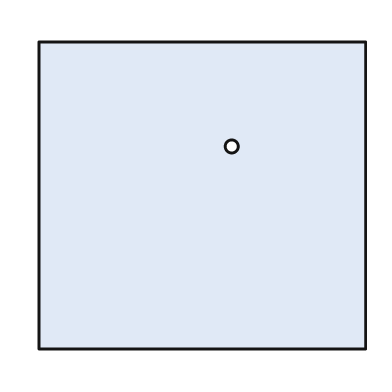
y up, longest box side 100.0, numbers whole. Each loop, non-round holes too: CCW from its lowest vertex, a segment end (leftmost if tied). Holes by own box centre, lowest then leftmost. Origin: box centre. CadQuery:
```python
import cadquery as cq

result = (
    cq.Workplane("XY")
    .moveTo(-50.0, -47.0)
    .lineTo(50.0, -47.0)
    .lineTo(50.0, 47.0)
    .lineTo(-50.0, 47.0)
    .close()
    .moveTo(9.0, 15.0)
    .circle(2.0)
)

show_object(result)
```